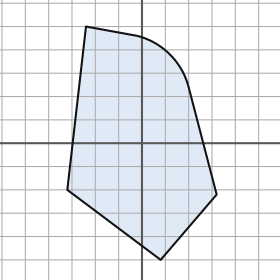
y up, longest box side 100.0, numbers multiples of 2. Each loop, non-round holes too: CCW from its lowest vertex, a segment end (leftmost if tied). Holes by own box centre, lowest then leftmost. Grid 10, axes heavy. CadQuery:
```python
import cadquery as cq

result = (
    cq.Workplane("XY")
    .moveTo(8.0, -50.0)
    .lineTo(32.0, -22.0)
    .lineTo(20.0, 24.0)
    .threePointArc((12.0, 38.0), (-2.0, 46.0))
    .lineTo(-24.0, 50.0)
    .lineTo(-32.0, -20.0)
    .close()
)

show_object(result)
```